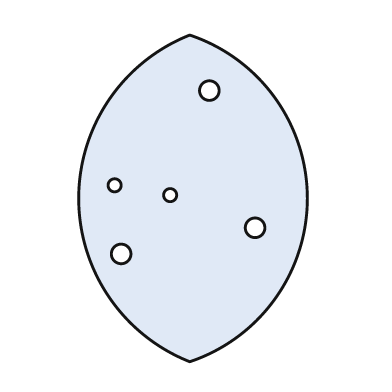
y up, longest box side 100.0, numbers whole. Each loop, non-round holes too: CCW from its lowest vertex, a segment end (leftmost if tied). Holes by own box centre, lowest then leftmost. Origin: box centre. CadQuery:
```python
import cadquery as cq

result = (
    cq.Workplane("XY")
    .moveTo(-1.0, -50.0)
    .threePointArc((35.0, 0.0), (-1.0, 50.0))
    .threePointArc((-35.0, 0.0), (-1.0, -50.0))
    .close()
    .moveTo(-22.0, -17.0)
    .circle(3.0)
    .moveTo(19.0, -9.0)
    .circle(3.0)
    .moveTo(-7.0, 1.0)
    .circle(2.0)
    .moveTo(-24.0, 4.0)
    .circle(2.0)
    .moveTo(5.0, 33.0)
    .circle(3.0)
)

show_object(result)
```